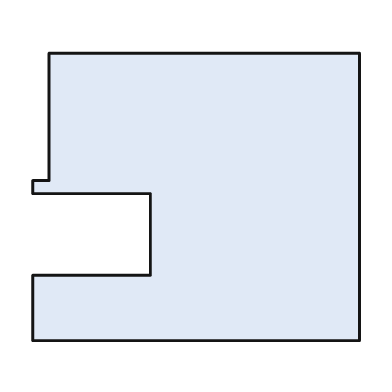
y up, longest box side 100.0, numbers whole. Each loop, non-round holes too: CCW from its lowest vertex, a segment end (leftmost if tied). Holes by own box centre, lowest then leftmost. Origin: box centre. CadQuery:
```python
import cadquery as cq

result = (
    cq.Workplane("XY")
    .moveTo(-50.0, -44.0)
    .lineTo(50.0, -44.0)
    .lineTo(50.0, 44.0)
    .lineTo(-45.0, 44.0)
    .lineTo(-45.0, 5.0)
    .lineTo(-50.0, 5.0)
    .lineTo(-50.0, 1.0)
    .lineTo(-14.0, 1.0)
    .lineTo(-14.0, -24.0)
    .lineTo(-50.0, -24.0)
    .close()
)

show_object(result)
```